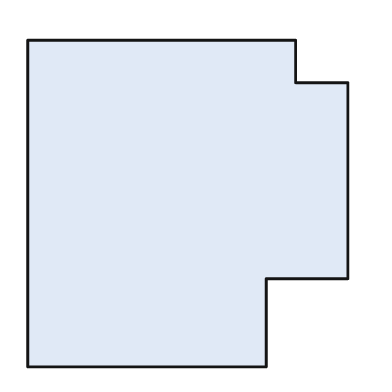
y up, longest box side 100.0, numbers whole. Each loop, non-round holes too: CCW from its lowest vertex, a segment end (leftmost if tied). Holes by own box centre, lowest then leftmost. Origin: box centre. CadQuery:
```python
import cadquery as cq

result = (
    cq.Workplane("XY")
    .moveTo(-49.0, -50.0)
    .lineTo(24.0, -50.0)
    .lineTo(24.0, -23.0)
    .lineTo(49.0, -23.0)
    .lineTo(49.0, 37.0)
    .lineTo(33.0, 37.0)
    .lineTo(33.0, 50.0)
    .lineTo(-49.0, 50.0)
    .close()
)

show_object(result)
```